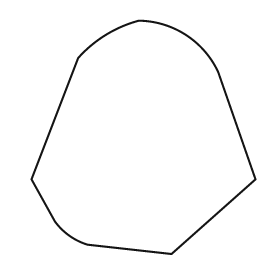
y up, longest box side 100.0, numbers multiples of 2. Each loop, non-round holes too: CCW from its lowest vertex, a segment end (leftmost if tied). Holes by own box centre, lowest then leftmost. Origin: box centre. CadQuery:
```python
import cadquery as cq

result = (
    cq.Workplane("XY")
    .moveTo(12.0, -50.0)
    .lineTo(48.0, -18.0)
    .lineTo(32.0, 28.0)
    .threePointArc((18.0, 44.0), (-2.0, 50.0))
    .threePointArc((-16.0, 44.0), (-28.0, 34.0))
    .lineTo(-48.0, -18.0)
    .lineTo(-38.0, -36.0)
    .threePointArc((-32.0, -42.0), (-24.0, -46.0))
    .close()
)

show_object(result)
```